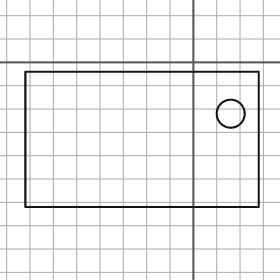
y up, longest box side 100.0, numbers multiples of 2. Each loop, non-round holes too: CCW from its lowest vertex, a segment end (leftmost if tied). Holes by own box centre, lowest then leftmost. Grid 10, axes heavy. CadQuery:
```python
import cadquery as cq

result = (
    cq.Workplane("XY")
    .moveTo(-72.0, -62.0)
    .lineTo(28.0, -62.0)
    .lineTo(28.0, -4.0)
    .lineTo(-72.0, -4.0)
    .close()
    .moveTo(16.0, -22.0)
    .circle(6.0)
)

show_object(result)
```